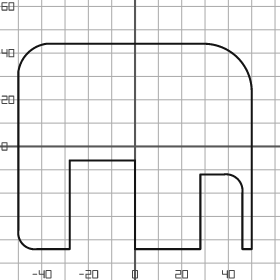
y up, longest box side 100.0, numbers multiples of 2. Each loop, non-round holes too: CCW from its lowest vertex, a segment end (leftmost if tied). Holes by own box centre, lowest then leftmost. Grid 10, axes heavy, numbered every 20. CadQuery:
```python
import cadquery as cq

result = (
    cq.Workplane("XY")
    .moveTo(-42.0, -44.0)
    .lineTo(-28.0, -44.0)
    .lineTo(-28.0, -6.0)
    .lineTo(0.0, -6.0)
    .lineTo(0.0, -44.0)
    .lineTo(28.0, -44.0)
    .lineTo(28.0, -12.0)
    .lineTo(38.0, -12.0)
    .threePointArc((44.0, -14.0), (46.0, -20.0))
    .lineTo(46.0, -44.0)
    .lineTo(50.0, -44.0)
    .lineTo(50.0, 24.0)
    .threePointArc((44.0, 38.0), (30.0, 44.0))
    .lineTo(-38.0, 44.0)
    .threePointArc((-46.0, 40.0), (-50.0, 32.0))
    .lineTo(-50.0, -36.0)
    .threePointArc((-48.0, -42.0), (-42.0, -44.0))
    .close()
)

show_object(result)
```